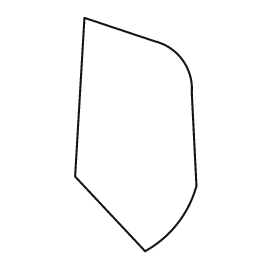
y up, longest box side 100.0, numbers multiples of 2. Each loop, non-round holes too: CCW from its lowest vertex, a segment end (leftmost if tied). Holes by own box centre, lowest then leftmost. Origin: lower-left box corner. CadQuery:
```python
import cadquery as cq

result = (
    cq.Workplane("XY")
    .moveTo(30.0, 0.0)
    .threePointArc((44.0, 12.0), (52.0, 28.0))
    .lineTo(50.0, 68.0)
    .threePointArc((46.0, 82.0), (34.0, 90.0))
    .lineTo(4.0, 100.0)
    .lineTo(0.0, 32.0)
    .close()
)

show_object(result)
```